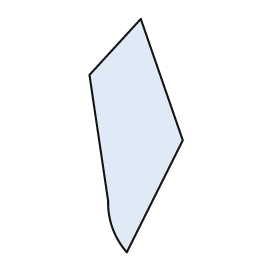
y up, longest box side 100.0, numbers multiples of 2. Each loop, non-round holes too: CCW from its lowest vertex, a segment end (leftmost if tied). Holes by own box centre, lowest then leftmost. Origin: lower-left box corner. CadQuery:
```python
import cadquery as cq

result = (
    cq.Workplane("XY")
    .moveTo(16.0, 0.0)
    .lineTo(40.0, 48.0)
    .lineTo(22.0, 100.0)
    .lineTo(0.0, 76.0)
    .lineTo(8.0, 22.0)
    .threePointArc((10.0, 10.0), (16.0, 0.0))
    .close()
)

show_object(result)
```